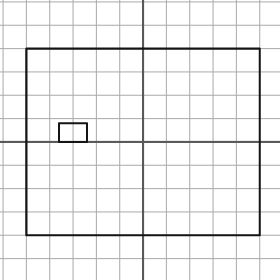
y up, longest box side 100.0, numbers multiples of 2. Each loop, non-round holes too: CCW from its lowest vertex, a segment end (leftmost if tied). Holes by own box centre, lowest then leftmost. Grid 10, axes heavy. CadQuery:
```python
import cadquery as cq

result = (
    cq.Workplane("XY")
    .moveTo(-50.0, -40.0)
    .lineTo(50.0, -40.0)
    .lineTo(50.0, 40.0)
    .lineTo(-50.0, 40.0)
    .close()
    .moveTo(-36.0, 0.0)
    .lineTo(-24.0, 0.0)
    .lineTo(-24.0, 8.0)
    .lineTo(-36.0, 8.0)
    .close()
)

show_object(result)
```